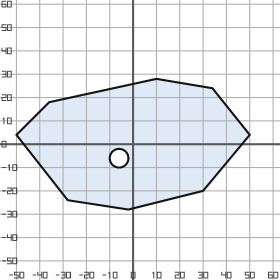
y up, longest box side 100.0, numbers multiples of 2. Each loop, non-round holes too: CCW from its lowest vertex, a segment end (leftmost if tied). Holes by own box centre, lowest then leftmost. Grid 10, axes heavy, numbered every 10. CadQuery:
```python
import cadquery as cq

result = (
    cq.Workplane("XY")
    .moveTo(-2.0, -28.0)
    .lineTo(30.0, -20.0)
    .lineTo(50.0, 4.0)
    .lineTo(34.0, 24.0)
    .lineTo(10.0, 28.0)
    .lineTo(-36.0, 18.0)
    .lineTo(-50.0, 4.0)
    .lineTo(-28.0, -24.0)
    .close()
    .moveTo(-6.0, -6.0)
    .circle(4.0)
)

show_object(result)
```